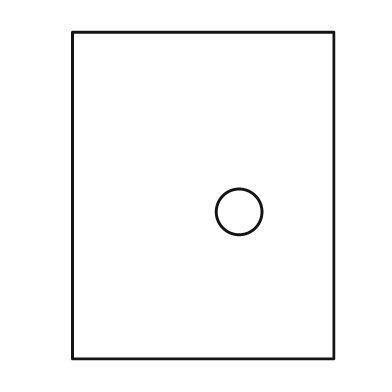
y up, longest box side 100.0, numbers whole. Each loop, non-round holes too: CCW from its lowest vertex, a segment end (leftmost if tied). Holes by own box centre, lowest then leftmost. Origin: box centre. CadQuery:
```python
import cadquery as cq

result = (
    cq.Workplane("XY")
    .moveTo(-40.0, -50.0)
    .lineTo(40.0, -50.0)
    .lineTo(40.0, 50.0)
    .lineTo(-40.0, 50.0)
    .close()
    .moveTo(11.0, -5.0)
    .circle(7.0)
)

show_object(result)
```